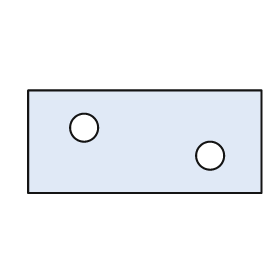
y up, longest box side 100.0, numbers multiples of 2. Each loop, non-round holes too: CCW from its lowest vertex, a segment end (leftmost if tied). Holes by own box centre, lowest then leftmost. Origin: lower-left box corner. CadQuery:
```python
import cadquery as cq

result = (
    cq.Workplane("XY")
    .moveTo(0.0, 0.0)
    .lineTo(100.0, 0.0)
    .lineTo(100.0, 44.0)
    .lineTo(0.0, 44.0)
    .close()
    .moveTo(78.0, 16.0)
    .circle(6.0)
    .moveTo(24.0, 28.0)
    .circle(6.0)
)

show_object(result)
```